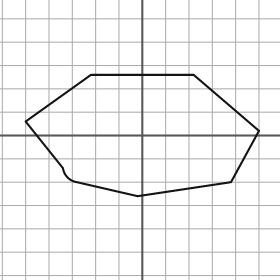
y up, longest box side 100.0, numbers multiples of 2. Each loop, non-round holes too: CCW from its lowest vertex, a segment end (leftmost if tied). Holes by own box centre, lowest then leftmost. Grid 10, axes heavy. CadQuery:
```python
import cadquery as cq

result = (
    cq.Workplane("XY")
    .moveTo(-2.0, -26.0)
    .lineTo(38.0, -20.0)
    .lineTo(50.0, 2.0)
    .lineTo(22.0, 26.0)
    .lineTo(-22.0, 26.0)
    .lineTo(-50.0, 6.0)
    .lineTo(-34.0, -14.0)
    .threePointArc((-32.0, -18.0), (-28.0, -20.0))
    .close()
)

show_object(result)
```